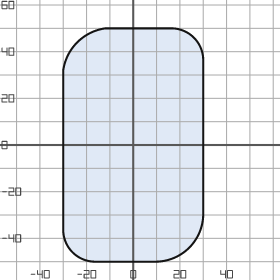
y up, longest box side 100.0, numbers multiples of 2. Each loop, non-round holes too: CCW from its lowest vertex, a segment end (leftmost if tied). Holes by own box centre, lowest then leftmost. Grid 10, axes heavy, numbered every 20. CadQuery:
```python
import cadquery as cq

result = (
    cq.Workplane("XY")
    .moveTo(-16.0, -50.0)
    .lineTo(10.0, -50.0)
    .threePointArc((24.0, -44.0), (30.0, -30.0))
    .lineTo(30.0, 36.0)
    .threePointArc((26.0, 46.0), (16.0, 50.0))
    .lineTo(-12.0, 50.0)
    .threePointArc((-24.0, 44.0), (-30.0, 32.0))
    .lineTo(-30.0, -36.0)
    .threePointArc((-26.0, -46.0), (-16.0, -50.0))
    .close()
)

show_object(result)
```